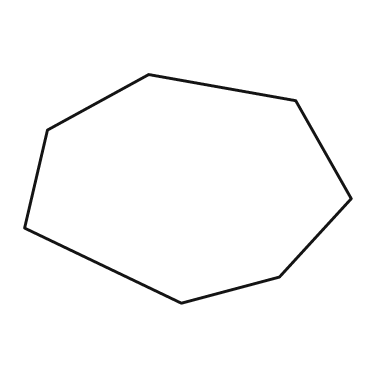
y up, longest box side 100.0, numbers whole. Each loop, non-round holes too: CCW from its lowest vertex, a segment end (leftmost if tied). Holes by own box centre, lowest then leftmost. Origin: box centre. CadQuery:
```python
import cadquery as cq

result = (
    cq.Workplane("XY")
    .moveTo(-2.0, -35.0)
    .lineTo(28.0, -27.0)
    .lineTo(50.0, -3.0)
    .lineTo(33.0, 27.0)
    .lineTo(-12.0, 35.0)
    .lineTo(-43.0, 18.0)
    .lineTo(-50.0, -12.0)
    .close()
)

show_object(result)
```